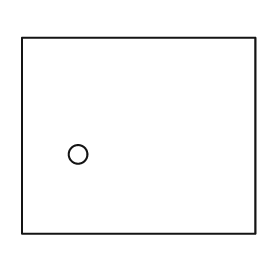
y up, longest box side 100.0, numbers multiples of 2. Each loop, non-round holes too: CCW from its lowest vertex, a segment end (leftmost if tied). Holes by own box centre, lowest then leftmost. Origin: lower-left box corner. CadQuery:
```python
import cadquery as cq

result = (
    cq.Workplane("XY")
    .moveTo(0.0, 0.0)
    .lineTo(100.0, 0.0)
    .lineTo(100.0, 84.0)
    .lineTo(0.0, 84.0)
    .close()
    .moveTo(24.0, 34.0)
    .circle(4.0)
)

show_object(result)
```